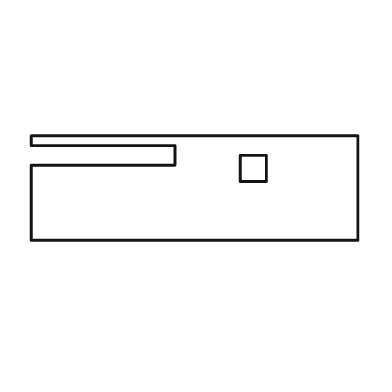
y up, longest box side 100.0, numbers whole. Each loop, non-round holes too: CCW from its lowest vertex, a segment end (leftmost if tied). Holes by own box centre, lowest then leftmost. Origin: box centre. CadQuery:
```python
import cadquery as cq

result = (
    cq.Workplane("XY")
    .moveTo(-50.0, -16.0)
    .lineTo(50.0, -16.0)
    .lineTo(50.0, 16.0)
    .lineTo(-50.0, 16.0)
    .lineTo(-50.0, 13.0)
    .lineTo(-6.0, 13.0)
    .lineTo(-6.0, 7.0)
    .lineTo(-50.0, 7.0)
    .close()
    .moveTo(14.0, 2.0)
    .lineTo(22.0, 2.0)
    .lineTo(22.0, 10.0)
    .lineTo(14.0, 10.0)
    .close()
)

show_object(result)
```